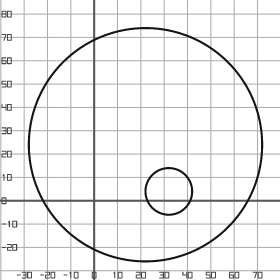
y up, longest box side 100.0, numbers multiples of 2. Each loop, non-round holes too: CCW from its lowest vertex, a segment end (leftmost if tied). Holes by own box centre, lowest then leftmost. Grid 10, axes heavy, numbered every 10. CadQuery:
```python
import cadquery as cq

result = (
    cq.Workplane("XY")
    .moveTo(22.0, 24.0)
    .circle(50.0)
    .moveTo(32.0, 4.0)
    .circle(10.0)
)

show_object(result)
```